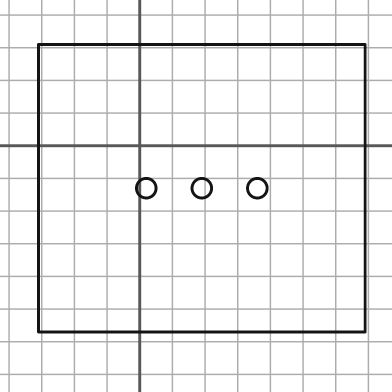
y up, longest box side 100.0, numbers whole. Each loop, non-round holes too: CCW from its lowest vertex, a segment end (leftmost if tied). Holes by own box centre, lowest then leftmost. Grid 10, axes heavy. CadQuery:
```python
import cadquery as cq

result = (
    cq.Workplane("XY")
    .moveTo(-31.0, -57.0)
    .lineTo(69.0, -57.0)
    .lineTo(69.0, 31.0)
    .lineTo(-31.0, 31.0)
    .close()
    .moveTo(2.0, -13.0)
    .circle(3.0)
    .moveTo(19.0, -13.0)
    .circle(3.0)
    .moveTo(36.0, -13.0)
    .circle(3.0)
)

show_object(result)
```